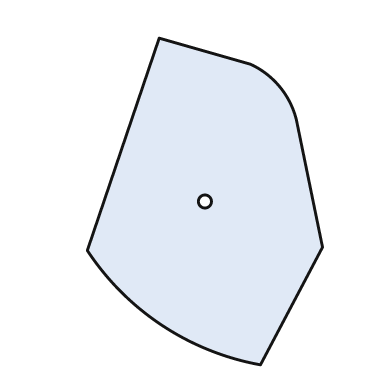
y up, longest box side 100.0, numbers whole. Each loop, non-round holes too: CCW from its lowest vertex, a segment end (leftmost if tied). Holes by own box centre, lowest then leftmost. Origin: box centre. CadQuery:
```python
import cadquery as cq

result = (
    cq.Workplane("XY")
    .moveTo(17.0, -50.0)
    .lineTo(36.0, -14.0)
    .lineTo(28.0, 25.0)
    .threePointArc((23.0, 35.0), (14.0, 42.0))
    .lineTo(-14.0, 50.0)
    .lineTo(-36.0, -15.0)
    .threePointArc((-13.0, -38.0), (17.0, -50.0))
    .close()
    .moveTo(0.0, 0.0)
    .circle(2.0)
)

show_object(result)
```